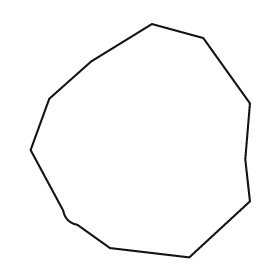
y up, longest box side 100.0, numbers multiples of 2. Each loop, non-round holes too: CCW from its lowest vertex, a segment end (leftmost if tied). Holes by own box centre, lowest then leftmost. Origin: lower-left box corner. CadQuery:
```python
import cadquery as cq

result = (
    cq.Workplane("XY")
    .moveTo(68.0, 0.0)
    .lineTo(94.0, 24.0)
    .lineTo(92.0, 42.0)
    .lineTo(94.0, 66.0)
    .lineTo(74.0, 94.0)
    .lineTo(52.0, 100.0)
    .lineTo(26.0, 84.0)
    .lineTo(8.0, 68.0)
    .lineTo(0.0, 46.0)
    .lineTo(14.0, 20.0)
    .threePointArc((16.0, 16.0), (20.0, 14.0))
    .lineTo(34.0, 4.0)
    .close()
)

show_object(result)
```